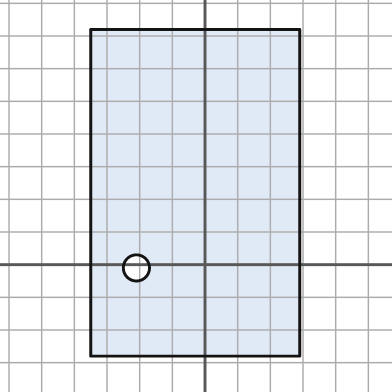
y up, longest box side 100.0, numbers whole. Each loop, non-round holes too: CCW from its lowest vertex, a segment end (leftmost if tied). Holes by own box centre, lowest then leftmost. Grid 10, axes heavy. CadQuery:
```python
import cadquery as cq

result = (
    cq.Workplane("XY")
    .moveTo(-35.0, -28.0)
    .lineTo(29.0, -28.0)
    .lineTo(29.0, 72.0)
    .lineTo(-35.0, 72.0)
    .close()
    .moveTo(-21.0, -1.0)
    .circle(4.0)
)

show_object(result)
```